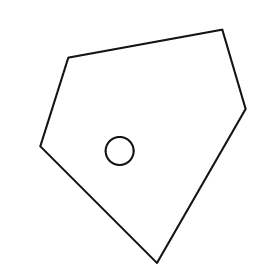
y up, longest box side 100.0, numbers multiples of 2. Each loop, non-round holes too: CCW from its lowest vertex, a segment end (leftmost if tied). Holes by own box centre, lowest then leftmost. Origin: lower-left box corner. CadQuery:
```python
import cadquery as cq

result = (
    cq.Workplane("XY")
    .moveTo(50.0, 0.0)
    .lineTo(88.0, 66.0)
    .lineTo(78.0, 100.0)
    .lineTo(12.0, 88.0)
    .lineTo(0.0, 50.0)
    .close()
    .moveTo(34.0, 48.0)
    .circle(6.0)
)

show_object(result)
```